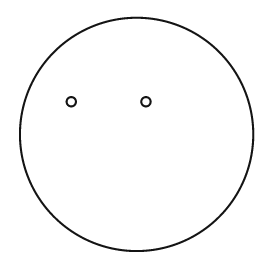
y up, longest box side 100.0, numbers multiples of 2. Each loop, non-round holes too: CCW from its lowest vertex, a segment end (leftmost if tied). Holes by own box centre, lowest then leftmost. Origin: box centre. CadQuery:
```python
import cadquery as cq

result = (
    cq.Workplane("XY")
    .moveTo(0.0, 0.0)
    .circle(50.0)
    .moveTo(-28.0, 14.0)
    .circle(2.0)
    .moveTo(4.0, 14.0)
    .circle(2.0)
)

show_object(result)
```